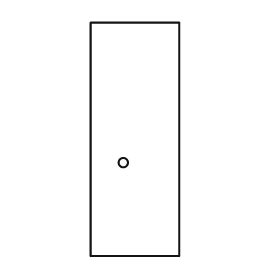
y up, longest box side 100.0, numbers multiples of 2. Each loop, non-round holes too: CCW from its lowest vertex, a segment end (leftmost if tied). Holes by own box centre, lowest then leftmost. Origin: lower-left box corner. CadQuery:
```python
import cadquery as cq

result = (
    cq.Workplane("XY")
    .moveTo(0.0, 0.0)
    .lineTo(38.0, 0.0)
    .lineTo(38.0, 100.0)
    .lineTo(0.0, 100.0)
    .close()
    .moveTo(14.0, 40.0)
    .circle(2.0)
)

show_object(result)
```